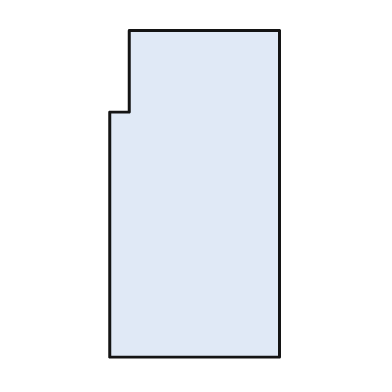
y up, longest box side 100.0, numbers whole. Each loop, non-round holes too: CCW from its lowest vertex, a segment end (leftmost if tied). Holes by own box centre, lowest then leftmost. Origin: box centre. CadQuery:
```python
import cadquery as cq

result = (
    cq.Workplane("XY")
    .moveTo(-26.0, -50.0)
    .lineTo(26.0, -50.0)
    .lineTo(26.0, 50.0)
    .lineTo(-20.0, 50.0)
    .lineTo(-20.0, 25.0)
    .lineTo(-26.0, 25.0)
    .close()
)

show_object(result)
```